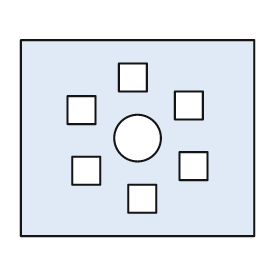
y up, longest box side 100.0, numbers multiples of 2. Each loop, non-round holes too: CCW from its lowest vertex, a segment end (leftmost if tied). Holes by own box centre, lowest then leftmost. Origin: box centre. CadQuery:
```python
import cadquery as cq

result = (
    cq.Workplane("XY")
    .moveTo(-50.0, -42.0)
    .lineTo(50.0, -42.0)
    .lineTo(50.0, 42.0)
    .lineTo(-50.0, 42.0)
    .close()
    .moveTo(-4.0, -32.0)
    .lineTo(8.0, -32.0)
    .lineTo(8.0, -20.0)
    .lineTo(-4.0, -20.0)
    .close()
    .moveTo(-28.0, -20.0)
    .lineTo(-16.0, -20.0)
    .lineTo(-16.0, -8.0)
    .lineTo(-28.0, -8.0)
    .close()
    .moveTo(18.0, -18.0)
    .lineTo(30.0, -18.0)
    .lineTo(30.0, -6.0)
    .lineTo(18.0, -6.0)
    .close()
    .moveTo(0.0, 0.0)
    .circle(10.0)
    .moveTo(-30.0, 6.0)
    .lineTo(-18.0, 6.0)
    .lineTo(-18.0, 18.0)
    .lineTo(-30.0, 18.0)
    .close()
    .moveTo(16.0, 8.0)
    .lineTo(28.0, 8.0)
    .lineTo(28.0, 20.0)
    .lineTo(16.0, 20.0)
    .close()
    .moveTo(-8.0, 20.0)
    .lineTo(4.0, 20.0)
    .lineTo(4.0, 32.0)
    .lineTo(-8.0, 32.0)
    .close()
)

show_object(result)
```